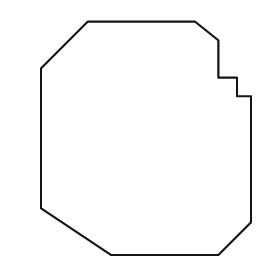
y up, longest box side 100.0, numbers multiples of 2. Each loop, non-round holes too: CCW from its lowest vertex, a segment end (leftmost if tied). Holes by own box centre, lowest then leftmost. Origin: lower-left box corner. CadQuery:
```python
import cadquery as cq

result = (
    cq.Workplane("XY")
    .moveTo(30.0, 0.0)
    .lineTo(76.0, 0.0)
    .lineTo(90.0, 14.0)
    .lineTo(90.0, 68.0)
    .lineTo(84.0, 68.0)
    .lineTo(84.0, 76.0)
    .lineTo(76.0, 76.0)
    .lineTo(76.0, 92.0)
    .lineTo(66.0, 100.0)
    .lineTo(20.0, 100.0)
    .lineTo(0.0, 80.0)
    .lineTo(0.0, 20.0)
    .close()
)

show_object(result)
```